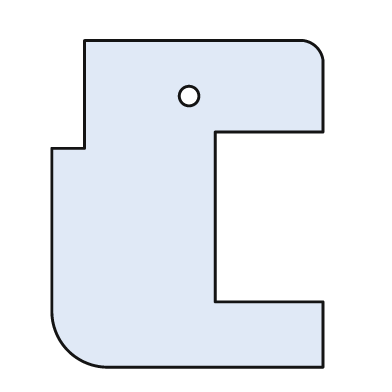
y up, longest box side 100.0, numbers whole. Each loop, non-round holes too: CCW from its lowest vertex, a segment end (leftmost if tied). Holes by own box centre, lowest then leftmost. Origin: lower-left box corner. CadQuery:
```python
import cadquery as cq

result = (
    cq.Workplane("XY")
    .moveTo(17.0, 0.0)
    .lineTo(83.0, 0.0)
    .lineTo(83.0, 20.0)
    .lineTo(50.0, 20.0)
    .lineTo(50.0, 72.0)
    .lineTo(83.0, 72.0)
    .lineTo(83.0, 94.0)
    .threePointArc((81.0, 98.0), (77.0, 100.0))
    .lineTo(10.0, 100.0)
    .lineTo(10.0, 67.0)
    .lineTo(0.0, 67.0)
    .lineTo(0.0, 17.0)
    .threePointArc((5.0, 5.0), (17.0, 0.0))
    .close()
    .moveTo(42.0, 83.0)
    .circle(3.0)
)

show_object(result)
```